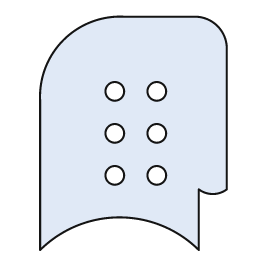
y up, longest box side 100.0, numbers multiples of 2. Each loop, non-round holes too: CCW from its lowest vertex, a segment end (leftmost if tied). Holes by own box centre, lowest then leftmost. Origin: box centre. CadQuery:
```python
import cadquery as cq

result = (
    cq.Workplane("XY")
    .moveTo(-40.0, -50.0)
    .threePointArc((-6.0, -36.0), (28.0, -50.0))
    .lineTo(28.0, -24.0)
    .threePointArc((34.0, -26.0), (40.0, -24.0))
    .lineTo(40.0, 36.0)
    .threePointArc((36.0, 46.0), (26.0, 50.0))
    .lineTo(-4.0, 50.0)
    .threePointArc((-30.0, 40.0), (-40.0, 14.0))
    .close()
    .moveTo(-8.0, -18.0)
    .circle(4.0)
    .moveTo(10.0, -18.0)
    .circle(4.0)
    .moveTo(-8.0, 0.0)
    .circle(4.0)
    .moveTo(10.0, 0.0)
    .circle(4.0)
    .moveTo(-8.0, 18.0)
    .circle(4.0)
    .moveTo(10.0, 18.0)
    .circle(4.0)
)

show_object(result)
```